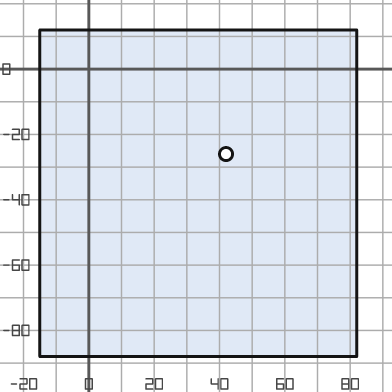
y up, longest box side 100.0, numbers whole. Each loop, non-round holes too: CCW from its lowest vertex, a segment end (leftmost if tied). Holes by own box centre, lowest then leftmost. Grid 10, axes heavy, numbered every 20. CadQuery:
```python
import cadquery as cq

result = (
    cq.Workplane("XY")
    .moveTo(-15.0, -88.0)
    .lineTo(82.0, -88.0)
    .lineTo(82.0, 12.0)
    .lineTo(-15.0, 12.0)
    .close()
    .moveTo(42.0, -26.0)
    .circle(2.0)
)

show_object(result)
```